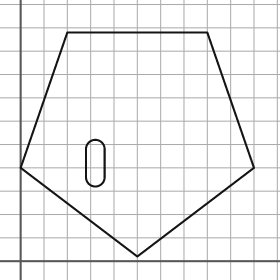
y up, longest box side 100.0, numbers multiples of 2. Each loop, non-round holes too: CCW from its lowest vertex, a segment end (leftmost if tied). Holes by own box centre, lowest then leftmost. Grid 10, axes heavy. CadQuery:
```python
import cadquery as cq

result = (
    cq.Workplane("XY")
    .moveTo(50.0, 2.0)
    .lineTo(100.0, 40.0)
    .lineTo(80.0, 98.0)
    .lineTo(20.0, 98.0)
    .lineTo(0.0, 40.0)
    .close()
    .moveTo(28.0, 36.0)
    .threePointArc((32.0, 32.0), (36.0, 36.0))
    .lineTo(36.0, 48.0)
    .threePointArc((32.0, 52.0), (28.0, 48.0))
    .close()
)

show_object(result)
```